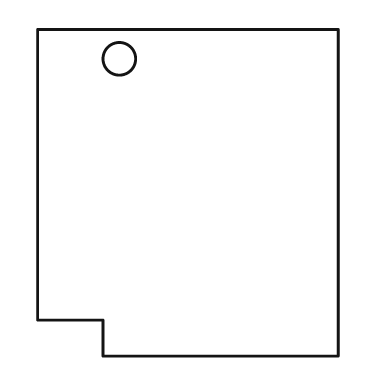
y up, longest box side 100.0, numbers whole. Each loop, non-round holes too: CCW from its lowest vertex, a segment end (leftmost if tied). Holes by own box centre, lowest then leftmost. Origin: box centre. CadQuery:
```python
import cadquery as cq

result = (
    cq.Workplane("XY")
    .moveTo(-26.0, -50.0)
    .lineTo(46.0, -50.0)
    .lineTo(46.0, 50.0)
    .lineTo(-46.0, 50.0)
    .lineTo(-46.0, -39.0)
    .lineTo(-26.0, -39.0)
    .close()
    .moveTo(-21.0, 41.0)
    .circle(5.0)
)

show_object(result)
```